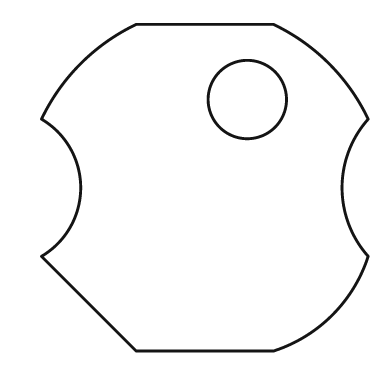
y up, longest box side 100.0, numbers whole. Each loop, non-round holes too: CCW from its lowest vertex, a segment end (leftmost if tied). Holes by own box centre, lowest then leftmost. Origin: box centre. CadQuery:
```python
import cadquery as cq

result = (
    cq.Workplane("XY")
    .moveTo(-21.0, -50.0)
    .lineTo(21.0, -50.0)
    .threePointArc((39.0, -39.0), (50.0, -21.0))
    .threePointArc((42.0, 0.0), (50.0, 21.0))
    .threePointArc((38.0, 38.0), (21.0, 50.0))
    .lineTo(-21.0, 50.0)
    .threePointArc((-38.0, 38.0), (-50.0, 21.0))
    .threePointArc((-38.0, 0.0), (-50.0, -21.0))
    .close()
    .moveTo(13.0, 27.0)
    .circle(12.0)
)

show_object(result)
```